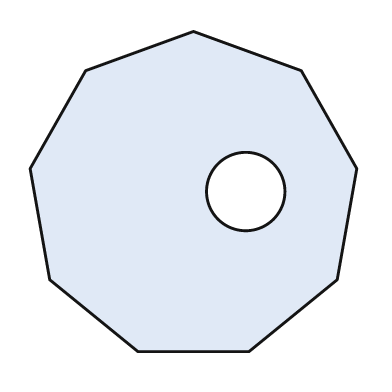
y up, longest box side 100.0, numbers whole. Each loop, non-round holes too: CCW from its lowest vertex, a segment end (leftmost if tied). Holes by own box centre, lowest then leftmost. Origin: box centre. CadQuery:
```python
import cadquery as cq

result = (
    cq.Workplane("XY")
    .moveTo(-17.0, -49.0)
    .lineTo(17.0, -49.0)
    .lineTo(44.0, -27.0)
    .lineTo(50.0, 7.0)
    .lineTo(33.0, 37.0)
    .lineTo(0.0, 49.0)
    .lineTo(-33.0, 37.0)
    .lineTo(-50.0, 7.0)
    .lineTo(-44.0, -27.0)
    .close()
    .moveTo(16.0, 0.0)
    .circle(12.0)
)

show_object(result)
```